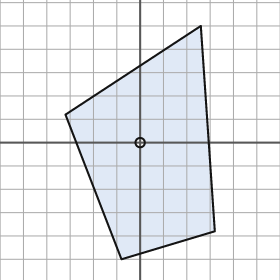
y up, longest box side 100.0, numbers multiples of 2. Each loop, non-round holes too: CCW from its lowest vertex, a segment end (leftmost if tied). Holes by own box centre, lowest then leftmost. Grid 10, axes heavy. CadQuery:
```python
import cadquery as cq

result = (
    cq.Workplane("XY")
    .moveTo(-8.0, -50.0)
    .lineTo(32.0, -38.0)
    .lineTo(26.0, 50.0)
    .lineTo(-32.0, 12.0)
    .close()
    .moveTo(0.0, 0.0)
    .circle(2.0)
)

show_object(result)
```